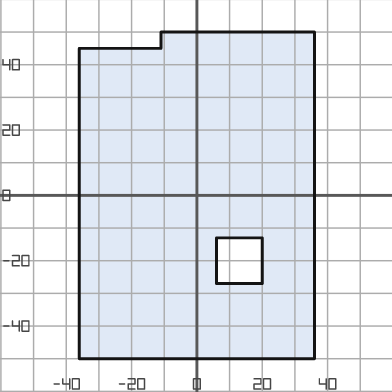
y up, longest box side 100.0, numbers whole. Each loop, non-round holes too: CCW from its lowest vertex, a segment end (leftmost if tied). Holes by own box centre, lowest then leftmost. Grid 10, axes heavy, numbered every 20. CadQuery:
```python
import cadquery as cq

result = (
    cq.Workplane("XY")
    .moveTo(-36.0, -50.0)
    .lineTo(36.0, -50.0)
    .lineTo(36.0, 50.0)
    .lineTo(-11.0, 50.0)
    .lineTo(-11.0, 45.0)
    .lineTo(-36.0, 45.0)
    .close()
    .moveTo(6.0, -27.0)
    .lineTo(20.0, -27.0)
    .lineTo(20.0, -13.0)
    .lineTo(6.0, -13.0)
    .close()
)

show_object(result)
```